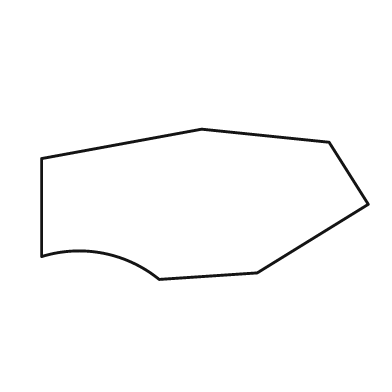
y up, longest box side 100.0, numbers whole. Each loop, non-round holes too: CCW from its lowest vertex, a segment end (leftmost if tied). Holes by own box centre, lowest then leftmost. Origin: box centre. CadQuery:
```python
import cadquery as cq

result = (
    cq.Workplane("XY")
    .moveTo(-14.0, -23.0)
    .lineTo(16.0, -21.0)
    .lineTo(50.0, 0.0)
    .lineTo(38.0, 19.0)
    .lineTo(-1.0, 23.0)
    .lineTo(-50.0, 14.0)
    .lineTo(-50.0, -16.0)
    .threePointArc((-31.0, -15.0), (-14.0, -23.0))
    .close()
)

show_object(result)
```